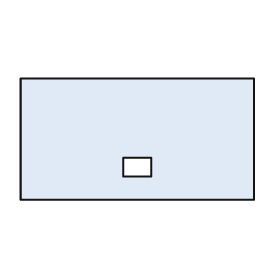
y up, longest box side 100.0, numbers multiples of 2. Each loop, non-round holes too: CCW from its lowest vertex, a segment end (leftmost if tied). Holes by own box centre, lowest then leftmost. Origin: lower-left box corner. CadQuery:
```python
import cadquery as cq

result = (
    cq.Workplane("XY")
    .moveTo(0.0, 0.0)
    .lineTo(100.0, 0.0)
    .lineTo(100.0, 52.0)
    .lineTo(0.0, 52.0)
    .close()
    .moveTo(44.0, 10.0)
    .lineTo(56.0, 10.0)
    .lineTo(56.0, 18.0)
    .lineTo(44.0, 18.0)
    .close()
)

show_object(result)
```